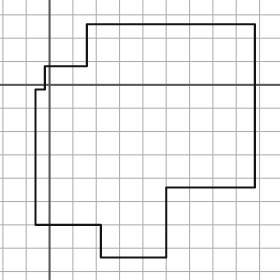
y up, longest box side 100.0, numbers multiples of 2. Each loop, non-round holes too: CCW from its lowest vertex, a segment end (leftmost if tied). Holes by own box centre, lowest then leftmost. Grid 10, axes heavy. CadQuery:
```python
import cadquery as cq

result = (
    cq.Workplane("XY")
    .moveTo(22.0, -74.0)
    .lineTo(50.0, -74.0)
    .lineTo(50.0, -44.0)
    .lineTo(88.0, -44.0)
    .lineTo(88.0, 26.0)
    .lineTo(16.0, 26.0)
    .lineTo(16.0, 8.0)
    .lineTo(-2.0, 8.0)
    .lineTo(-2.0, -2.0)
    .lineTo(-6.0, -2.0)
    .lineTo(-6.0, -60.0)
    .lineTo(22.0, -60.0)
    .close()
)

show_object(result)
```